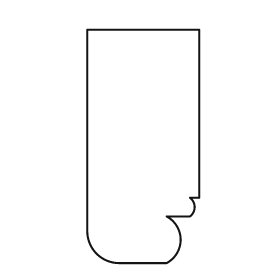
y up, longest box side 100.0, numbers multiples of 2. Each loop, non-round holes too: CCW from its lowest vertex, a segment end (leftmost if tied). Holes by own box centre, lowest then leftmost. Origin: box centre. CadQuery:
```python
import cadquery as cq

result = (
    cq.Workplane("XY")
    .moveTo(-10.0, -50.0)
    .lineTo(10.0, -50.0)
    .threePointArc((16.0, -40.0), (10.0, -30.0))
    .lineTo(20.0, -30.0)
    .threePointArc((22.0, -26.0), (20.0, -22.0))
    .lineTo(24.0, -22.0)
    .lineTo(24.0, 50.0)
    .lineTo(-24.0, 50.0)
    .lineTo(-24.0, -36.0)
    .threePointArc((-20.0, -46.0), (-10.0, -50.0))
    .close()
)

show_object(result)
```